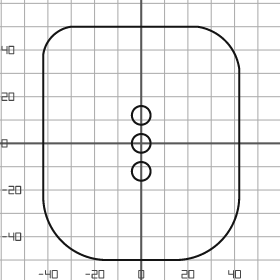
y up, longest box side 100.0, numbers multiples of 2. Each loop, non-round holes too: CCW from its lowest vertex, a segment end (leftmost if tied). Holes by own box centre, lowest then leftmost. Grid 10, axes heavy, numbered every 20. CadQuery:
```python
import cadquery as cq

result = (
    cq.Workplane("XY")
    .moveTo(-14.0, -50.0)
    .lineTo(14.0, -50.0)
    .threePointArc((34.0, -42.0), (42.0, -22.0))
    .lineTo(42.0, 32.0)
    .threePointArc((36.0, 44.0), (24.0, 50.0))
    .lineTo(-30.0, 50.0)
    .threePointArc((-38.0, 46.0), (-42.0, 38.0))
    .lineTo(-42.0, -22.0)
    .threePointArc((-34.0, -42.0), (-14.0, -50.0))
    .close()
    .moveTo(0.0, -12.0)
    .circle(4.0)
    .moveTo(0.0, 0.0)
    .circle(4.0)
    .moveTo(0.0, 12.0)
    .circle(4.0)
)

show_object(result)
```